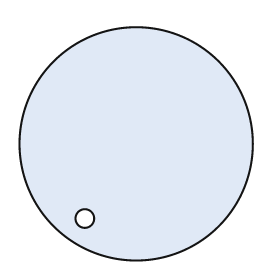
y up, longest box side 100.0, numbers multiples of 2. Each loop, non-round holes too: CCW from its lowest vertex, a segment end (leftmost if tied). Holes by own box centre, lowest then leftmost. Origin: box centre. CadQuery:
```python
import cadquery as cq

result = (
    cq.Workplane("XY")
    .moveTo(0.0, 0.0)
    .circle(50.0)
    .moveTo(-22.0, -32.0)
    .circle(4.0)
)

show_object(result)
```